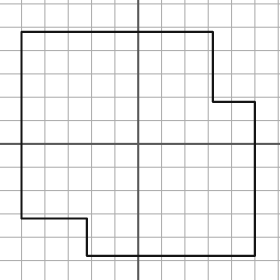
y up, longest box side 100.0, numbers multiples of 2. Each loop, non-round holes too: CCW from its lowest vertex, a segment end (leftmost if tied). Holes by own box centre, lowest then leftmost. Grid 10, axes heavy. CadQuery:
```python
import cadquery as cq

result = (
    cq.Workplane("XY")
    .moveTo(-22.0, -48.0)
    .lineTo(50.0, -48.0)
    .lineTo(50.0, 18.0)
    .lineTo(32.0, 18.0)
    .lineTo(32.0, 48.0)
    .lineTo(-50.0, 48.0)
    .lineTo(-50.0, -32.0)
    .lineTo(-22.0, -32.0)
    .close()
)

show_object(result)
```